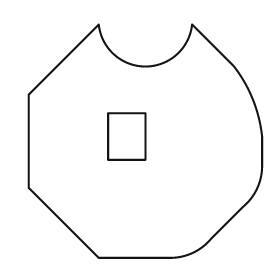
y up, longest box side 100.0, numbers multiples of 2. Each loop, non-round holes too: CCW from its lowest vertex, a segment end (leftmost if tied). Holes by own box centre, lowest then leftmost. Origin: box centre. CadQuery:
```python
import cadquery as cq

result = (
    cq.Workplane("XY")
    .moveTo(-20.0, -50.0)
    .lineTo(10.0, -50.0)
    .threePointArc((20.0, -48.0), (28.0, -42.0))
    .lineTo(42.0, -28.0)
    .threePointArc((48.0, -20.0), (50.0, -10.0))
    .lineTo(50.0, 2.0)
    .threePointArc((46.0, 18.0), (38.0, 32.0))
    .lineTo(20.0, 50.0)
    .threePointArc((0.0, 32.0), (-20.0, 50.0))
    .lineTo(-50.0, 20.0)
    .lineTo(-50.0, -20.0)
    .close()
    .moveTo(-16.0, -8.0)
    .lineTo(0.0, -8.0)
    .lineTo(0.0, 12.0)
    .lineTo(-16.0, 12.0)
    .close()
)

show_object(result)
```